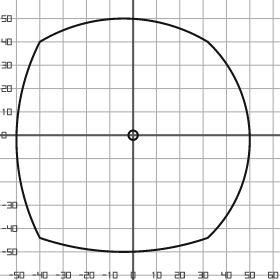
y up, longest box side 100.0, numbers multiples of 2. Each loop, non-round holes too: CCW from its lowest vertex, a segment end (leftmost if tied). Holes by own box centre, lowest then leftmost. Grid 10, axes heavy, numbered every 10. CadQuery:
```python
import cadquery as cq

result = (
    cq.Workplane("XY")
    .moveTo(-40.0, -44.0)
    .threePointArc((-4.0, -50.0), (32.0, -44.0))
    .threePointArc((50.0, -2.0), (32.0, 40.0))
    .threePointArc((-4.0, 50.0), (-40.0, 40.0))
    .threePointArc((-50.0, -2.0), (-40.0, -44.0))
    .close()
    .moveTo(0.0, 0.0)
    .circle(2.0)
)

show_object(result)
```